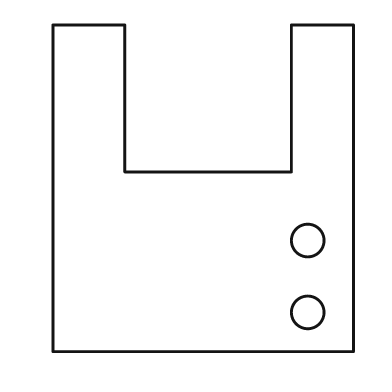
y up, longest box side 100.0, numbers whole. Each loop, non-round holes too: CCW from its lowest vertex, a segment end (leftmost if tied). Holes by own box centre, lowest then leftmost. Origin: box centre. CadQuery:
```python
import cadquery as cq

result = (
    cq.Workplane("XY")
    .moveTo(-46.0, -50.0)
    .lineTo(46.0, -50.0)
    .lineTo(46.0, 50.0)
    .lineTo(27.0, 50.0)
    .lineTo(27.0, 5.0)
    .lineTo(-24.0, 5.0)
    .lineTo(-24.0, 50.0)
    .lineTo(-46.0, 50.0)
    .close()
    .moveTo(32.0, -38.0)
    .circle(5.0)
    .moveTo(32.0, -16.0)
    .circle(5.0)
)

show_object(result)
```